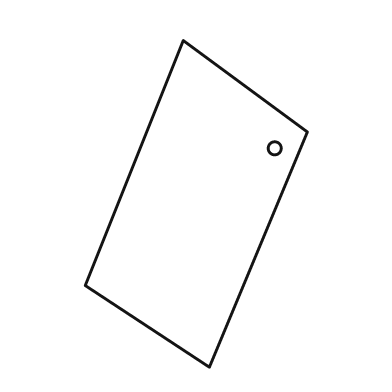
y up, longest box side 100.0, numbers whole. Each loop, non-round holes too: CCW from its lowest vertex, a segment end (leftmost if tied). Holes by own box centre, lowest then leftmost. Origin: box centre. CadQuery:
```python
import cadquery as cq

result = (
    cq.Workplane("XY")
    .moveTo(4.0, -50.0)
    .lineTo(34.0, 22.0)
    .lineTo(-4.0, 50.0)
    .lineTo(-34.0, -25.0)
    .close()
    .moveTo(24.0, 17.0)
    .circle(2.0)
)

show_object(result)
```